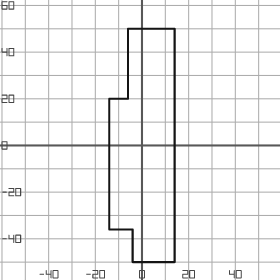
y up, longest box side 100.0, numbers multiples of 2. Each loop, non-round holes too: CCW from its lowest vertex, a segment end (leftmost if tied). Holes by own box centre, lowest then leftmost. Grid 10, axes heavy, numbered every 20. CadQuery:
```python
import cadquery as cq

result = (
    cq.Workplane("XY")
    .moveTo(-4.0, -50.0)
    .lineTo(14.0, -50.0)
    .lineTo(14.0, 50.0)
    .lineTo(-6.0, 50.0)
    .lineTo(-6.0, 20.0)
    .lineTo(-14.0, 20.0)
    .lineTo(-14.0, -36.0)
    .lineTo(-4.0, -36.0)
    .close()
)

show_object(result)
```